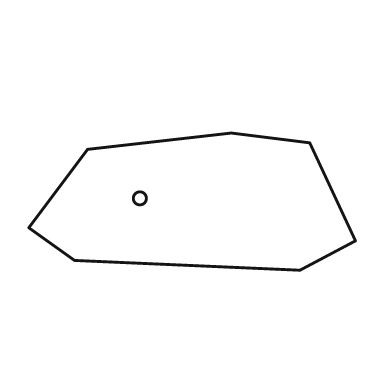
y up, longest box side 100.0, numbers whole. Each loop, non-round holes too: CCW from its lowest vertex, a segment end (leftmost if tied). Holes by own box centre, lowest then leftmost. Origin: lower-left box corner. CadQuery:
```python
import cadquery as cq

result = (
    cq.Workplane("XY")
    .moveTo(83.0, 0.0)
    .lineTo(100.0, 9.0)
    .lineTo(86.0, 39.0)
    .lineTo(62.0, 42.0)
    .lineTo(18.0, 37.0)
    .lineTo(0.0, 13.0)
    .lineTo(14.0, 3.0)
    .close()
    .moveTo(34.0, 22.0)
    .circle(2.0)
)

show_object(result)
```